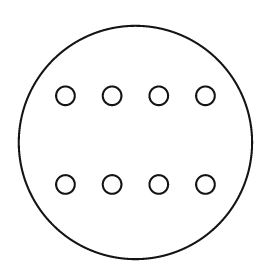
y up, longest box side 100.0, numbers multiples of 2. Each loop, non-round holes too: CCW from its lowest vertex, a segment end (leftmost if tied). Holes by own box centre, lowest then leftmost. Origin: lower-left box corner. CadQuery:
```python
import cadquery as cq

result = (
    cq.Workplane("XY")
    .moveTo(50.0, 50.0)
    .circle(50.0)
    .moveTo(20.0, 32.0)
    .circle(4.0)
    .moveTo(40.0, 32.0)
    .circle(4.0)
    .moveTo(60.0, 32.0)
    .circle(4.0)
    .moveTo(80.0, 32.0)
    .circle(4.0)
    .moveTo(20.0, 70.0)
    .circle(4.0)
    .moveTo(40.0, 70.0)
    .circle(4.0)
    .moveTo(60.0, 70.0)
    .circle(4.0)
    .moveTo(80.0, 70.0)
    .circle(4.0)
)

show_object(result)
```